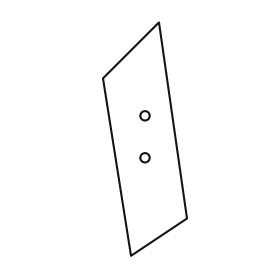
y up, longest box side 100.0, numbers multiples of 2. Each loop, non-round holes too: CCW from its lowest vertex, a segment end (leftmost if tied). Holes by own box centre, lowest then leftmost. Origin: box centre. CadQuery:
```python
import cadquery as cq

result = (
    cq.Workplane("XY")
    .moveTo(-6.0, -50.0)
    .lineTo(18.0, -34.0)
    .lineTo(6.0, 50.0)
    .lineTo(-18.0, 26.0)
    .close()
    .moveTo(0.0, -8.0)
    .circle(2.0)
    .moveTo(0.0, 10.0)
    .circle(2.0)
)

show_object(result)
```